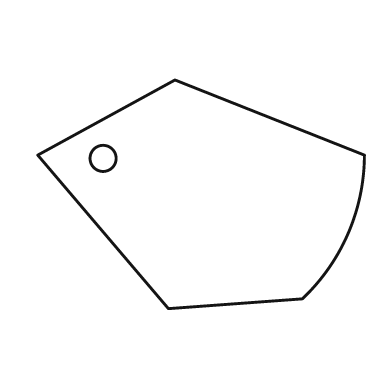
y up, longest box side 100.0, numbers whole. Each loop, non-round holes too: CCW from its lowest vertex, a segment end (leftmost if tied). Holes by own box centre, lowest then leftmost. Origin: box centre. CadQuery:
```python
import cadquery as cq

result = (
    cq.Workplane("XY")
    .moveTo(-10.0, -35.0)
    .lineTo(31.0, -32.0)
    .threePointArc((45.0, -12.0), (50.0, 12.0))
    .lineTo(-8.0, 35.0)
    .lineTo(-50.0, 12.0)
    .close()
    .moveTo(-30.0, 11.0)
    .circle(4.0)
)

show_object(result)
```